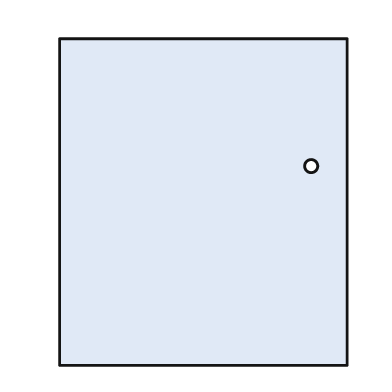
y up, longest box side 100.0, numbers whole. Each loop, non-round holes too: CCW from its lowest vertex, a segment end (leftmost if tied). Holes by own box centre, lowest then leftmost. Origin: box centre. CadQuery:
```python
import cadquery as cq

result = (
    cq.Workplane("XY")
    .moveTo(-44.0, -50.0)
    .lineTo(44.0, -50.0)
    .lineTo(44.0, 50.0)
    .lineTo(-44.0, 50.0)
    .close()
    .moveTo(33.0, 11.0)
    .circle(2.0)
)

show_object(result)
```